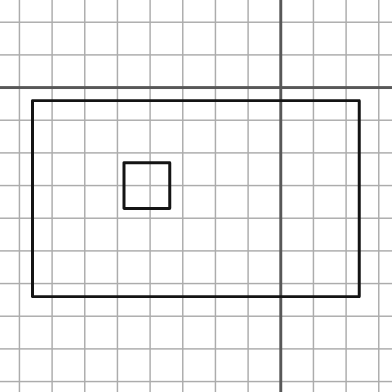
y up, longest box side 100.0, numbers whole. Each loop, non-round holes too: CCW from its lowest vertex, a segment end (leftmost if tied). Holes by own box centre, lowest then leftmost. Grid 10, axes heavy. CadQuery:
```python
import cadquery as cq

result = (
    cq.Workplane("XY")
    .moveTo(-76.0, -64.0)
    .lineTo(24.0, -64.0)
    .lineTo(24.0, -4.0)
    .lineTo(-76.0, -4.0)
    .close()
    .moveTo(-48.0, -37.0)
    .lineTo(-34.0, -37.0)
    .lineTo(-34.0, -23.0)
    .lineTo(-48.0, -23.0)
    .close()
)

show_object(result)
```